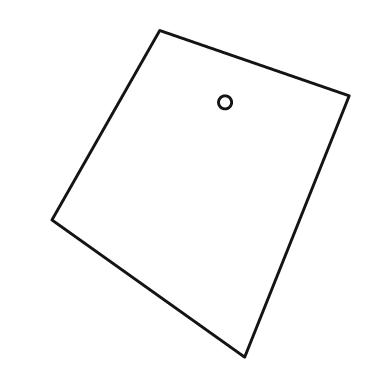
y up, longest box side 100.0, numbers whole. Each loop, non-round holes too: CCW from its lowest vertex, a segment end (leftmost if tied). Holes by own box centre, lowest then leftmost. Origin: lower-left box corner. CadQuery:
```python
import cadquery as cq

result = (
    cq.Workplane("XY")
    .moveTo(59.0, 0.0)
    .lineTo(91.0, 80.0)
    .lineTo(33.0, 100.0)
    .lineTo(0.0, 42.0)
    .close()
    .moveTo(53.0, 78.0)
    .circle(2.0)
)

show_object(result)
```